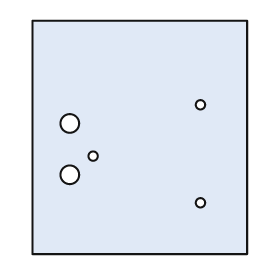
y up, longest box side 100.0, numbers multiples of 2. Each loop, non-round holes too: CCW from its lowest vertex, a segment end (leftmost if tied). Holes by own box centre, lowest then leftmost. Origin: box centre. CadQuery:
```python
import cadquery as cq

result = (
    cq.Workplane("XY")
    .moveTo(-46.0, -50.0)
    .lineTo(46.0, -50.0)
    .lineTo(46.0, 50.0)
    .lineTo(-46.0, 50.0)
    .close()
    .moveTo(26.0, -28.0)
    .circle(2.0)
    .moveTo(-30.0, -16.0)
    .circle(4.0)
    .moveTo(-20.0, -8.0)
    .circle(2.0)
    .moveTo(-30.0, 6.0)
    .circle(4.0)
    .moveTo(26.0, 14.0)
    .circle(2.0)
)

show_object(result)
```